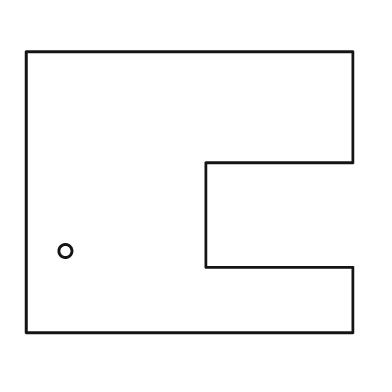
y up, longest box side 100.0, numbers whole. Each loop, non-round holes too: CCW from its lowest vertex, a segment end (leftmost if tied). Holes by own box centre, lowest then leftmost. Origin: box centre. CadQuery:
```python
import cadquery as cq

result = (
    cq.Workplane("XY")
    .moveTo(-50.0, -43.0)
    .lineTo(50.0, -43.0)
    .lineTo(50.0, -23.0)
    .lineTo(5.0, -23.0)
    .lineTo(5.0, 9.0)
    .lineTo(50.0, 9.0)
    .lineTo(50.0, 43.0)
    .lineTo(-50.0, 43.0)
    .close()
    .moveTo(-38.0, -18.0)
    .circle(2.0)
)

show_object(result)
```